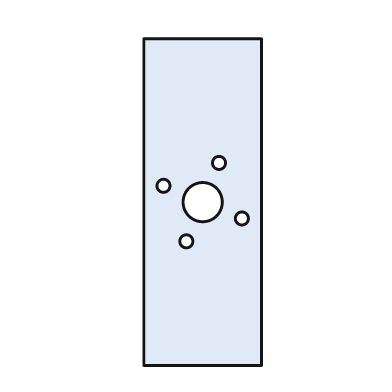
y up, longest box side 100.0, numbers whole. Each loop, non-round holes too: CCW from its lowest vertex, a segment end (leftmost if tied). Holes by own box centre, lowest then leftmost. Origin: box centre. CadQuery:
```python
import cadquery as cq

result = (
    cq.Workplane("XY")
    .moveTo(-18.0, -50.0)
    .lineTo(18.0, -50.0)
    .lineTo(18.0, 50.0)
    .lineTo(-18.0, 50.0)
    .close()
    .moveTo(-5.0, -12.0)
    .circle(2.0)
    .moveTo(12.0, -5.0)
    .circle(2.0)
    .moveTo(0.0, 0.0)
    .circle(6.0)
    .moveTo(-12.0, 5.0)
    .circle(2.0)
    .moveTo(5.0, 12.0)
    .circle(2.0)
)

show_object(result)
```